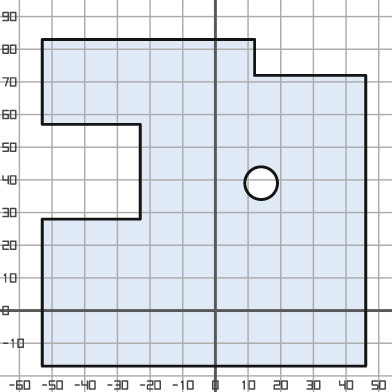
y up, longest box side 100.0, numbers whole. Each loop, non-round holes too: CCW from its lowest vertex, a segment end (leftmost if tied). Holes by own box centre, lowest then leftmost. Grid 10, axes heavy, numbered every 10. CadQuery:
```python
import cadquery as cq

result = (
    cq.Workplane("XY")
    .moveTo(-53.0, -17.0)
    .lineTo(46.0, -17.0)
    .lineTo(46.0, 72.0)
    .lineTo(12.0, 72.0)
    .lineTo(12.0, 83.0)
    .lineTo(-53.0, 83.0)
    .lineTo(-53.0, 57.0)
    .lineTo(-23.0, 57.0)
    .lineTo(-23.0, 28.0)
    .lineTo(-53.0, 28.0)
    .close()
    .moveTo(14.0, 39.0)
    .circle(5.0)
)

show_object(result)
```